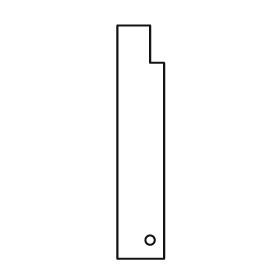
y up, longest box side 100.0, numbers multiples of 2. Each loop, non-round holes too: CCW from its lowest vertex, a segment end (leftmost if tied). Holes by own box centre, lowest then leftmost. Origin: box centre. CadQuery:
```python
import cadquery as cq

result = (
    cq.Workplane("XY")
    .moveTo(-10.0, -50.0)
    .lineTo(10.0, -50.0)
    .lineTo(10.0, 34.0)
    .lineTo(4.0, 34.0)
    .lineTo(4.0, 50.0)
    .lineTo(-10.0, 50.0)
    .close()
    .moveTo(4.0, -42.0)
    .circle(2.0)
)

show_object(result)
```